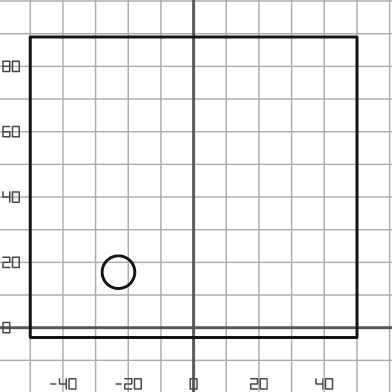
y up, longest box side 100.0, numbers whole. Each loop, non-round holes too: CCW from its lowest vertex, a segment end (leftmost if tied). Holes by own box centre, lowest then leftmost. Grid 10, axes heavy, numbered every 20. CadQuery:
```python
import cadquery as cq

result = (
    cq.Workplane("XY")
    .moveTo(-50.0, -3.0)
    .lineTo(50.0, -3.0)
    .lineTo(50.0, 89.0)
    .lineTo(-50.0, 89.0)
    .close()
    .moveTo(-23.0, 17.0)
    .circle(5.0)
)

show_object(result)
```